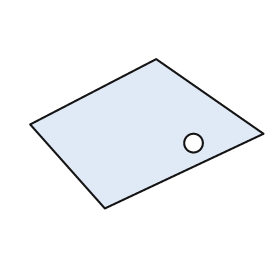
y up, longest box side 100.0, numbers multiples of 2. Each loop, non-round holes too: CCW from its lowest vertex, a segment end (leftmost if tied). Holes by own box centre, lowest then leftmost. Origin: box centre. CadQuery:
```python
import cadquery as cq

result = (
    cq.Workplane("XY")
    .moveTo(-18.0, -32.0)
    .lineTo(50.0, 0.0)
    .lineTo(4.0, 32.0)
    .lineTo(-50.0, 4.0)
    .close()
    .moveTo(20.0, -4.0)
    .circle(4.0)
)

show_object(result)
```